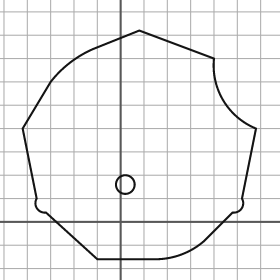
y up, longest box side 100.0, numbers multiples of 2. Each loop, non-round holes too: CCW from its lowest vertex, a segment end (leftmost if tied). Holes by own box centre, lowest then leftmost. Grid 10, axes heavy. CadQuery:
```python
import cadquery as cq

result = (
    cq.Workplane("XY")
    .moveTo(-10.0, -16.0)
    .lineTo(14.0, -16.0)
    .threePointArc((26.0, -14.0), (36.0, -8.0))
    .lineTo(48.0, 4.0)
    .threePointArc((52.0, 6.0), (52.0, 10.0))
    .lineTo(58.0, 40.0)
    .threePointArc((44.0, 52.0), (40.0, 70.0))
    .lineTo(8.0, 82.0)
    .lineTo(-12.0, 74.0)
    .threePointArc((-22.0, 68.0), (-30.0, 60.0))
    .lineTo(-42.0, 40.0)
    .lineTo(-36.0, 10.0)
    .threePointArc((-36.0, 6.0), (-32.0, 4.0))
    .close()
    .moveTo(2.0, 16.0)
    .circle(4.0)
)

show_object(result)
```